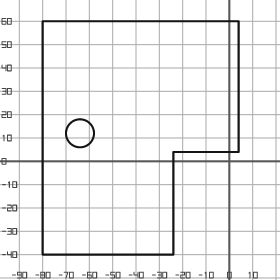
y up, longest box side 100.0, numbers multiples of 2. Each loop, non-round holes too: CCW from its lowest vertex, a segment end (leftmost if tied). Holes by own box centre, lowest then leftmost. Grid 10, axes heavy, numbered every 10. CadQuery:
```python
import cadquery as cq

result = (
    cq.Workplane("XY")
    .moveTo(-80.0, -40.0)
    .lineTo(-24.0, -40.0)
    .lineTo(-24.0, 4.0)
    .lineTo(4.0, 4.0)
    .lineTo(4.0, 60.0)
    .lineTo(-80.0, 60.0)
    .close()
    .moveTo(-64.0, 12.0)
    .circle(6.0)
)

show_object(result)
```